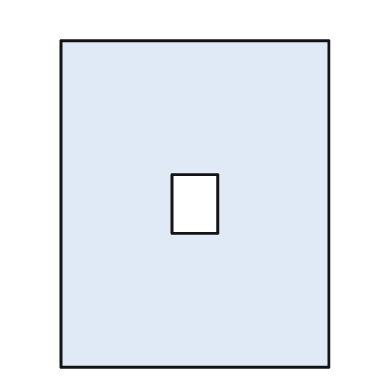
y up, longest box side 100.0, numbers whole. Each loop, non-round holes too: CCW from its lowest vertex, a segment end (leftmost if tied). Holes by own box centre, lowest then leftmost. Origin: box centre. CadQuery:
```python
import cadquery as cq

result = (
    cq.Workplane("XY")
    .moveTo(-41.0, -50.0)
    .lineTo(41.0, -50.0)
    .lineTo(41.0, 50.0)
    .lineTo(-41.0, 50.0)
    .close()
    .moveTo(-7.0, -9.0)
    .lineTo(7.0, -9.0)
    .lineTo(7.0, 9.0)
    .lineTo(-7.0, 9.0)
    .close()
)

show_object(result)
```